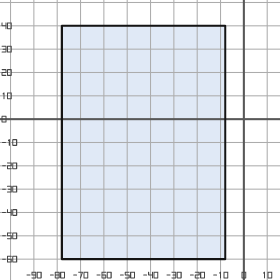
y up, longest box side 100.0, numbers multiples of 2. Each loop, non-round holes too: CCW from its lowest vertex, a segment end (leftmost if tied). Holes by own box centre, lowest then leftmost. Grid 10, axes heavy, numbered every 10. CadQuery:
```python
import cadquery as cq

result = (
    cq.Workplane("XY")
    .moveTo(-78.0, -60.0)
    .lineTo(-8.0, -60.0)
    .lineTo(-8.0, 40.0)
    .lineTo(-78.0, 40.0)
    .close()
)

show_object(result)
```